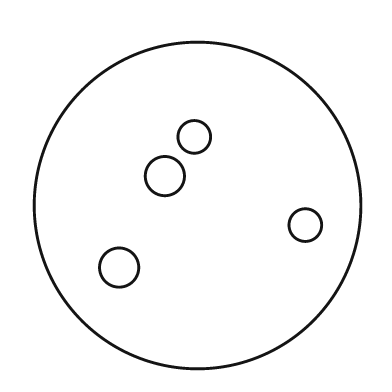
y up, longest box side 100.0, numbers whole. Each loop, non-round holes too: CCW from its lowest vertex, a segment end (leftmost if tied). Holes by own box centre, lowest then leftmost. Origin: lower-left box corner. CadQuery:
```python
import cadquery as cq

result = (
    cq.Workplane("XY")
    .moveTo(50.0, 50.0)
    .circle(50.0)
    .moveTo(26.0, 31.0)
    .circle(6.0)
    .moveTo(83.0, 44.0)
    .circle(5.0)
    .moveTo(40.0, 59.0)
    .circle(6.0)
    .moveTo(49.0, 71.0)
    .circle(5.0)
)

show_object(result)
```